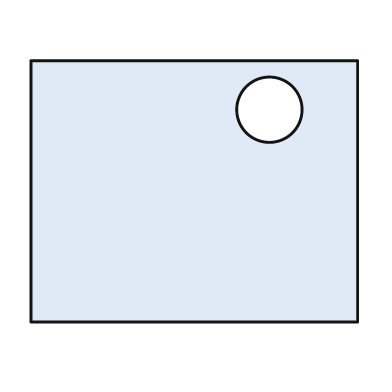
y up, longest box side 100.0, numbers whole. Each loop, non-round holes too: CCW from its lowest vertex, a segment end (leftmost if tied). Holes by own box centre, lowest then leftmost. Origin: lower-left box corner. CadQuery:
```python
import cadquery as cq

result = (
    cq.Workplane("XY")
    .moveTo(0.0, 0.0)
    .lineTo(100.0, 0.0)
    .lineTo(100.0, 80.0)
    .lineTo(0.0, 80.0)
    .close()
    .moveTo(73.0, 65.0)
    .circle(10.0)
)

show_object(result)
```